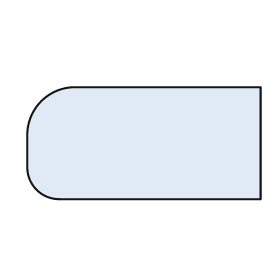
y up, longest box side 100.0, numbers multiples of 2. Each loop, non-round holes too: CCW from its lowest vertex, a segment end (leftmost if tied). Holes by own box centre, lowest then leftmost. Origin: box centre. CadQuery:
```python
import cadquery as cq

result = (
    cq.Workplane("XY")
    .moveTo(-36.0, -24.0)
    .lineTo(50.0, -24.0)
    .lineTo(50.0, 24.0)
    .lineTo(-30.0, 24.0)
    .threePointArc((-44.0, 18.0), (-50.0, 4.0))
    .lineTo(-50.0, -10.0)
    .threePointArc((-46.0, -20.0), (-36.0, -24.0))
    .close()
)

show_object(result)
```